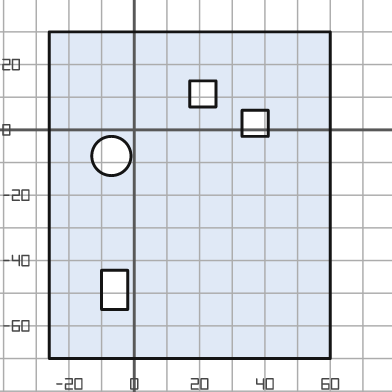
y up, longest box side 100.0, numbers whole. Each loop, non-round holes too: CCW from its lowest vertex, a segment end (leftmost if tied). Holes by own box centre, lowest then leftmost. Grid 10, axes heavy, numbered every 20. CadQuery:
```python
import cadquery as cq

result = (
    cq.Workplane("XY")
    .moveTo(-26.0, -70.0)
    .lineTo(60.0, -70.0)
    .lineTo(60.0, 30.0)
    .lineTo(-26.0, 30.0)
    .close()
    .moveTo(-10.0, -55.0)
    .lineTo(-2.0, -55.0)
    .lineTo(-2.0, -43.0)
    .lineTo(-10.0, -43.0)
    .close()
    .moveTo(-7.0, -8.0)
    .circle(6.0)
    .moveTo(33.0, -2.0)
    .lineTo(41.0, -2.0)
    .lineTo(41.0, 6.0)
    .lineTo(33.0, 6.0)
    .close()
    .moveTo(17.0, 7.0)
    .lineTo(25.0, 7.0)
    .lineTo(25.0, 15.0)
    .lineTo(17.0, 15.0)
    .close()
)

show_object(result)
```